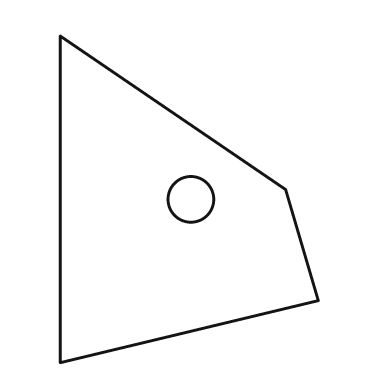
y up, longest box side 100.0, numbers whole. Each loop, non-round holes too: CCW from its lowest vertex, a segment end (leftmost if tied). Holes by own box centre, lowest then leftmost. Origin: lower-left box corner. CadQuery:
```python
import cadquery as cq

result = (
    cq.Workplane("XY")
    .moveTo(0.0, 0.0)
    .lineTo(79.0, 19.0)
    .lineTo(69.0, 53.0)
    .lineTo(0.0, 100.0)
    .close()
    .moveTo(40.0, 50.0)
    .circle(7.0)
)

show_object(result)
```